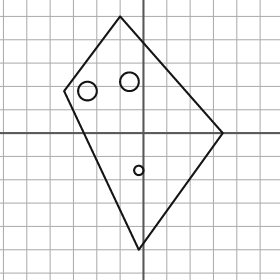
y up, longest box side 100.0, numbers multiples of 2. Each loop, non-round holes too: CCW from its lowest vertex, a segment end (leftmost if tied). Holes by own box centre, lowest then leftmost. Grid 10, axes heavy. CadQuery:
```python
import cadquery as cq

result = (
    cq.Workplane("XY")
    .moveTo(-2.0, -50.0)
    .lineTo(34.0, 0.0)
    .lineTo(-10.0, 50.0)
    .lineTo(-34.0, 18.0)
    .close()
    .moveTo(-2.0, -16.0)
    .circle(2.0)
    .moveTo(-24.0, 18.0)
    .circle(4.0)
    .moveTo(-6.0, 22.0)
    .circle(4.0)
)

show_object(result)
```